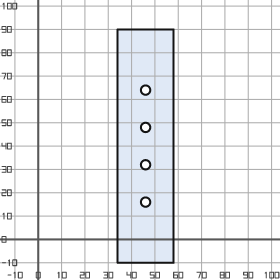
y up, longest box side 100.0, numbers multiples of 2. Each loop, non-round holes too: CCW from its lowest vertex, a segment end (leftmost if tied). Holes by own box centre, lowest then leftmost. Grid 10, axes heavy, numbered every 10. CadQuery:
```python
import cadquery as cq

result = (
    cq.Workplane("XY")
    .moveTo(34.0, -10.0)
    .lineTo(58.0, -10.0)
    .lineTo(58.0, 90.0)
    .lineTo(34.0, 90.0)
    .close()
    .moveTo(46.0, 16.0)
    .circle(2.0)
    .moveTo(46.0, 32.0)
    .circle(2.0)
    .moveTo(46.0, 48.0)
    .circle(2.0)
    .moveTo(46.0, 64.0)
    .circle(2.0)
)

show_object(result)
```